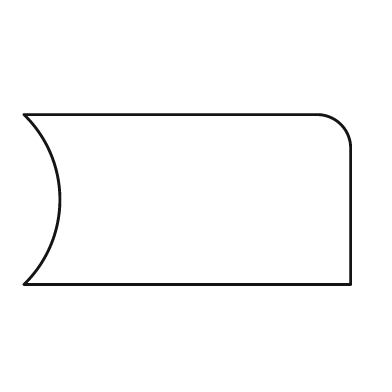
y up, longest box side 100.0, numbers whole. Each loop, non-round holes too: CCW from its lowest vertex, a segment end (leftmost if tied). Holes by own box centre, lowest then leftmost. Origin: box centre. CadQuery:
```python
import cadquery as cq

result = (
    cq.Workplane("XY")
    .moveTo(-50.0, -26.0)
    .lineTo(50.0, -26.0)
    .lineTo(50.0, 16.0)
    .threePointArc((47.0, 23.0), (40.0, 26.0))
    .lineTo(-50.0, 26.0)
    .threePointArc((-39.0, 0.0), (-50.0, -26.0))
    .close()
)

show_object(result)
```